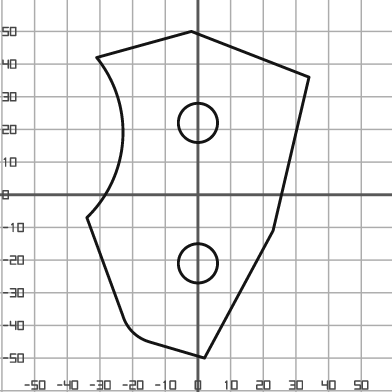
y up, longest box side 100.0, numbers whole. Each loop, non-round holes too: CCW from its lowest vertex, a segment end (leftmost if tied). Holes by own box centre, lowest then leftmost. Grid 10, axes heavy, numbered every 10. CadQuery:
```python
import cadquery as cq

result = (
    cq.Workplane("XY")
    .moveTo(2.0, -50.0)
    .lineTo(23.0, -11.0)
    .lineTo(34.0, 36.0)
    .lineTo(-2.0, 50.0)
    .lineTo(-31.0, 42.0)
    .threePointArc((-23.0, 17.0), (-34.0, -7.0))
    .lineTo(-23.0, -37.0)
    .threePointArc((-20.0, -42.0), (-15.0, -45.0))
    .close()
    .moveTo(0.0, -21.0)
    .circle(6.0)
    .moveTo(0.0, 22.0)
    .circle(6.0)
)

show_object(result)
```